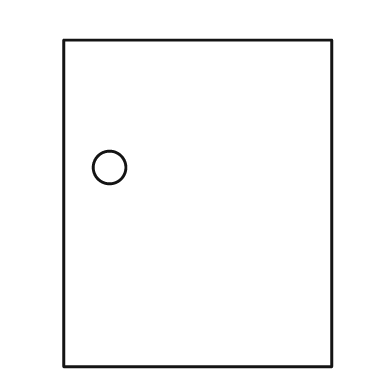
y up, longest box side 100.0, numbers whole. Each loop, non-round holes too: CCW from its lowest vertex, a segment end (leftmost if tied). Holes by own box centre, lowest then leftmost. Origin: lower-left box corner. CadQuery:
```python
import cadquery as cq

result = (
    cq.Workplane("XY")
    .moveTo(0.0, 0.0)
    .lineTo(82.0, 0.0)
    .lineTo(82.0, 100.0)
    .lineTo(0.0, 100.0)
    .close()
    .moveTo(14.0, 61.0)
    .circle(5.0)
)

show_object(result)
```